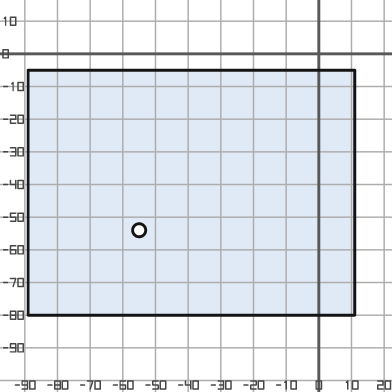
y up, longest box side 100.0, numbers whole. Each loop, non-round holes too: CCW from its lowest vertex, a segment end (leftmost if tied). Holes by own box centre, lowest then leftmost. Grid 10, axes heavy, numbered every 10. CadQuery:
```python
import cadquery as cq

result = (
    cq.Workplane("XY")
    .moveTo(-89.0, -80.0)
    .lineTo(11.0, -80.0)
    .lineTo(11.0, -5.0)
    .lineTo(-89.0, -5.0)
    .close()
    .moveTo(-55.0, -54.0)
    .circle(2.0)
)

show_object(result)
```